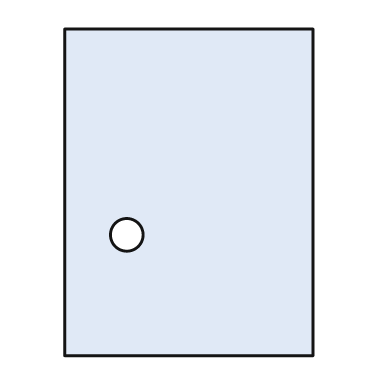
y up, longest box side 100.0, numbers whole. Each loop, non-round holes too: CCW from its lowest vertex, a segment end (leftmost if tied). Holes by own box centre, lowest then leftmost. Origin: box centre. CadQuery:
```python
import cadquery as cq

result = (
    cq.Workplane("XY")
    .moveTo(-38.0, -50.0)
    .lineTo(38.0, -50.0)
    .lineTo(38.0, 50.0)
    .lineTo(-38.0, 50.0)
    .close()
    .moveTo(-19.0, -13.0)
    .circle(5.0)
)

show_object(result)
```